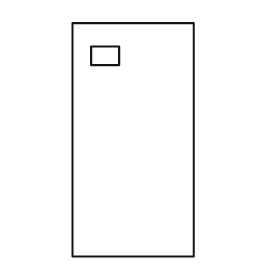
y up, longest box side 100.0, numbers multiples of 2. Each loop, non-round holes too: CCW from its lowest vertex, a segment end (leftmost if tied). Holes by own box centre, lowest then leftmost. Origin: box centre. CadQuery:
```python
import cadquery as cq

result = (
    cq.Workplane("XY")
    .moveTo(-26.0, -50.0)
    .lineTo(26.0, -50.0)
    .lineTo(26.0, 50.0)
    .lineTo(-26.0, 50.0)
    .close()
    .moveTo(-18.0, 32.0)
    .lineTo(-6.0, 32.0)
    .lineTo(-6.0, 40.0)
    .lineTo(-18.0, 40.0)
    .close()
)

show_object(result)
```